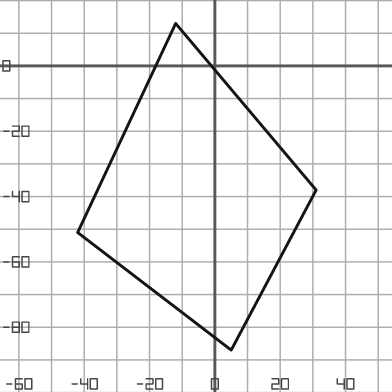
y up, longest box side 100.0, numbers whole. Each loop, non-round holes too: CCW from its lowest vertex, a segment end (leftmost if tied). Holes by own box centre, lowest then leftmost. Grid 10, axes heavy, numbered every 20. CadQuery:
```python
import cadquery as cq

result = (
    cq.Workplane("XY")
    .moveTo(5.0, -87.0)
    .lineTo(31.0, -38.0)
    .lineTo(-12.0, 13.0)
    .lineTo(-42.0, -51.0)
    .close()
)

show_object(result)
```